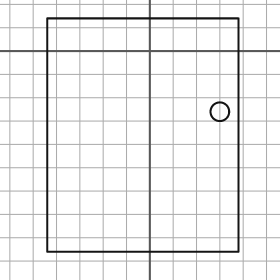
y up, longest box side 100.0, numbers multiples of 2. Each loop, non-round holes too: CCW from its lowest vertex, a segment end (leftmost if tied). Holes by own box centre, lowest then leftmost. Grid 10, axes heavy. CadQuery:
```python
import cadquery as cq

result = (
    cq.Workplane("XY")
    .moveTo(-44.0, -86.0)
    .lineTo(38.0, -86.0)
    .lineTo(38.0, 14.0)
    .lineTo(-44.0, 14.0)
    .close()
    .moveTo(30.0, -26.0)
    .circle(4.0)
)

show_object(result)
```